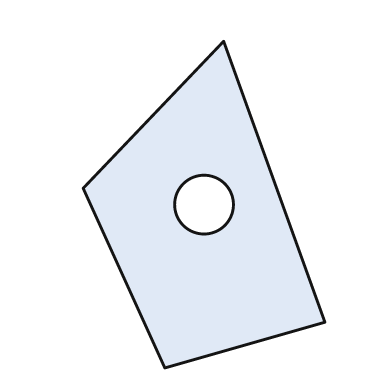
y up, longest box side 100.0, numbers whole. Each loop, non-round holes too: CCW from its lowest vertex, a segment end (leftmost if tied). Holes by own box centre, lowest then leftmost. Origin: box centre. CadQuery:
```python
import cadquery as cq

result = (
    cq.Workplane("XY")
    .moveTo(-12.0, -50.0)
    .lineTo(37.0, -36.0)
    .lineTo(6.0, 50.0)
    .lineTo(-37.0, 5.0)
    .close()
    .moveTo(0.0, 0.0)
    .circle(9.0)
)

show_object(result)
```